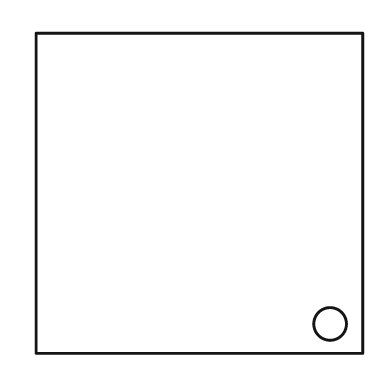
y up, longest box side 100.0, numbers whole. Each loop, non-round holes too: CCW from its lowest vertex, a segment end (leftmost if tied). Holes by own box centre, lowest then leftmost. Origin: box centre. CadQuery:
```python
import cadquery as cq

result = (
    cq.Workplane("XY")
    .moveTo(-50.0, -49.0)
    .lineTo(50.0, -49.0)
    .lineTo(50.0, 49.0)
    .lineTo(-50.0, 49.0)
    .close()
    .moveTo(40.0, -40.0)
    .circle(5.0)
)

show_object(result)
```